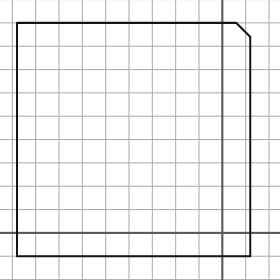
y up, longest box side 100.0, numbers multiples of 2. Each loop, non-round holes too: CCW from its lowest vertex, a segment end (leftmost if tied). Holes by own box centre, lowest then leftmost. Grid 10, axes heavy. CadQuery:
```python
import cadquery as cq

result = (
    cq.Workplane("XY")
    .moveTo(-88.0, -10.0)
    .lineTo(12.0, -10.0)
    .lineTo(12.0, 84.0)
    .lineTo(6.0, 90.0)
    .lineTo(-88.0, 90.0)
    .close()
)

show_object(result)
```